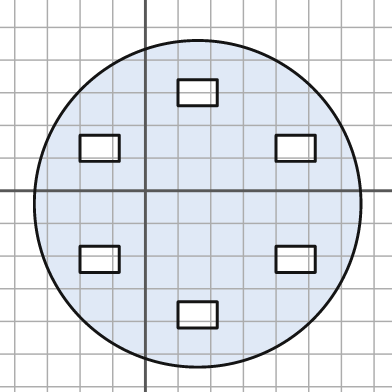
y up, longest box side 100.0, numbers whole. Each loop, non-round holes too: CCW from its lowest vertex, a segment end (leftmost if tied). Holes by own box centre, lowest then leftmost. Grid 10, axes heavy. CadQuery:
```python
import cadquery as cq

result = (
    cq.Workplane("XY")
    .moveTo(16.0, -4.0)
    .circle(50.0)
    .moveTo(10.0, -42.0)
    .lineTo(22.0, -42.0)
    .lineTo(22.0, -34.0)
    .lineTo(10.0, -34.0)
    .close()
    .moveTo(-20.0, -25.0)
    .lineTo(-8.0, -25.0)
    .lineTo(-8.0, -17.0)
    .lineTo(-20.0, -17.0)
    .close()
    .moveTo(40.0, -25.0)
    .lineTo(52.0, -25.0)
    .lineTo(52.0, -17.0)
    .lineTo(40.0, -17.0)
    .close()
    .moveTo(-20.0, 9.0)
    .lineTo(-8.0, 9.0)
    .lineTo(-8.0, 17.0)
    .lineTo(-20.0, 17.0)
    .close()
    .moveTo(40.0, 9.0)
    .lineTo(52.0, 9.0)
    .lineTo(52.0, 17.0)
    .lineTo(40.0, 17.0)
    .close()
    .moveTo(10.0, 26.0)
    .lineTo(22.0, 26.0)
    .lineTo(22.0, 34.0)
    .lineTo(10.0, 34.0)
    .close()
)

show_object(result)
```